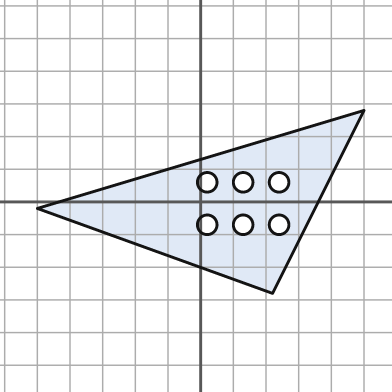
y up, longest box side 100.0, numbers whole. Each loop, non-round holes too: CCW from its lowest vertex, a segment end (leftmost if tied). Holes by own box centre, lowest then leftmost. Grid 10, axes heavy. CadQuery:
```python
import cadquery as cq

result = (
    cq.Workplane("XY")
    .moveTo(22.0, -28.0)
    .lineTo(50.0, 28.0)
    .lineTo(-50.0, -2.0)
    .close()
    .moveTo(2.0, -7.0)
    .circle(3.0)
    .moveTo(13.0, -7.0)
    .circle(3.0)
    .moveTo(24.0, -7.0)
    .circle(3.0)
    .moveTo(2.0, 6.0)
    .circle(3.0)
    .moveTo(13.0, 6.0)
    .circle(3.0)
    .moveTo(24.0, 6.0)
    .circle(3.0)
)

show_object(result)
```